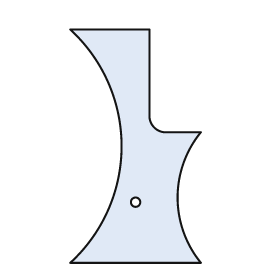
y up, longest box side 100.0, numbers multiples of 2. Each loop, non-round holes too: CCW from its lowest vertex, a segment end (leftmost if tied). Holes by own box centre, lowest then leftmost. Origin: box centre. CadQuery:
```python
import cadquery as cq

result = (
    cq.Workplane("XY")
    .moveTo(-28.0, -50.0)
    .lineTo(28.0, -50.0)
    .threePointArc((18.0, -22.0), (28.0, 6.0))
    .lineTo(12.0, 6.0)
    .threePointArc((8.0, 8.0), (6.0, 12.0))
    .lineTo(6.0, 50.0)
    .lineTo(-28.0, 50.0)
    .threePointArc((-6.0, 0.0), (-28.0, -50.0))
    .close()
    .moveTo(0.0, -24.0)
    .circle(2.0)
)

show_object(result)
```